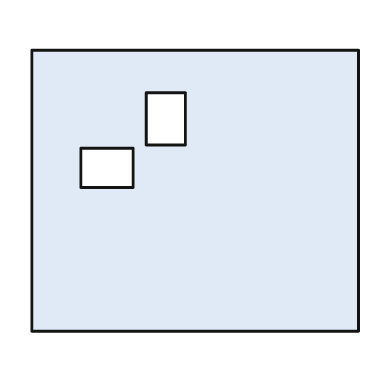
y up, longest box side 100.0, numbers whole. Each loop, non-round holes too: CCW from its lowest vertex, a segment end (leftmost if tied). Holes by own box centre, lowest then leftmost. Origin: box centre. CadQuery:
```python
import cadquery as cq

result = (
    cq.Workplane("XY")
    .moveTo(-50.0, -43.0)
    .lineTo(50.0, -43.0)
    .lineTo(50.0, 43.0)
    .lineTo(-50.0, 43.0)
    .close()
    .moveTo(-35.0, 1.0)
    .lineTo(-19.0, 1.0)
    .lineTo(-19.0, 13.0)
    .lineTo(-35.0, 13.0)
    .close()
    .moveTo(-15.0, 14.0)
    .lineTo(-3.0, 14.0)
    .lineTo(-3.0, 30.0)
    .lineTo(-15.0, 30.0)
    .close()
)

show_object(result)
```